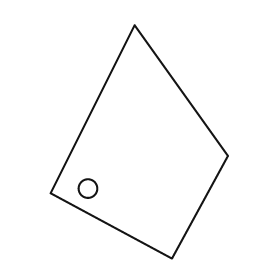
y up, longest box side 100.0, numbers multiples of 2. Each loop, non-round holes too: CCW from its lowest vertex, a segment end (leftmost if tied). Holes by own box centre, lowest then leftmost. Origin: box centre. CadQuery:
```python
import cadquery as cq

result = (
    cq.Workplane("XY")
    .moveTo(14.0, -50.0)
    .lineTo(38.0, -6.0)
    .lineTo(-2.0, 50.0)
    .lineTo(-38.0, -22.0)
    .close()
    .moveTo(-22.0, -20.0)
    .circle(4.0)
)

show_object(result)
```